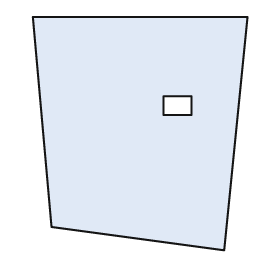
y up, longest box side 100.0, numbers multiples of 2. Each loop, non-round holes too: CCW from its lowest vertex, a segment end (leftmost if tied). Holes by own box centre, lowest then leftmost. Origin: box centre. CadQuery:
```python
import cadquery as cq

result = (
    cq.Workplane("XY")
    .moveTo(36.0, -50.0)
    .lineTo(46.0, 50.0)
    .lineTo(-46.0, 50.0)
    .lineTo(-38.0, -40.0)
    .close()
    .moveTo(10.0, 8.0)
    .lineTo(22.0, 8.0)
    .lineTo(22.0, 16.0)
    .lineTo(10.0, 16.0)
    .close()
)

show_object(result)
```